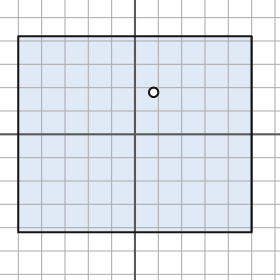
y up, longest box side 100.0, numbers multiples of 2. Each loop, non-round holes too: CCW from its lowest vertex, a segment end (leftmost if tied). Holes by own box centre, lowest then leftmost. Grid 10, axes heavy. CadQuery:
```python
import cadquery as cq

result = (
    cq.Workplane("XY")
    .moveTo(-50.0, -42.0)
    .lineTo(50.0, -42.0)
    .lineTo(50.0, 42.0)
    .lineTo(-50.0, 42.0)
    .close()
    .moveTo(8.0, 18.0)
    .circle(2.0)
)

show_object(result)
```